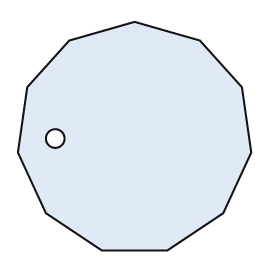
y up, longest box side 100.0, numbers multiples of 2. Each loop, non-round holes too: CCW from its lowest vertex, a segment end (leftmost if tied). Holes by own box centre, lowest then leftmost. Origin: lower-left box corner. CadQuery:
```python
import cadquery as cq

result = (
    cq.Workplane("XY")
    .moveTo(36.0, 0.0)
    .lineTo(64.0, 0.0)
    .lineTo(88.0, 16.0)
    .lineTo(100.0, 42.0)
    .lineTo(96.0, 70.0)
    .lineTo(78.0, 90.0)
    .lineTo(50.0, 98.0)
    .lineTo(22.0, 90.0)
    .lineTo(4.0, 70.0)
    .lineTo(0.0, 42.0)
    .lineTo(12.0, 16.0)
    .close()
    .moveTo(16.0, 48.0)
    .circle(4.0)
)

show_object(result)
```